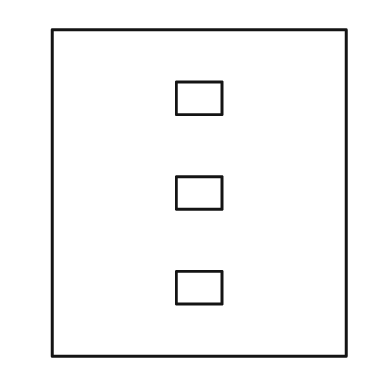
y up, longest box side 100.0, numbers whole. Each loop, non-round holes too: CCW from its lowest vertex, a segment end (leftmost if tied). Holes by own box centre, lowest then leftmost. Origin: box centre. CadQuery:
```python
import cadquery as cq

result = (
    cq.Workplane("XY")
    .moveTo(-45.0, -50.0)
    .lineTo(45.0, -50.0)
    .lineTo(45.0, 50.0)
    .lineTo(-45.0, 50.0)
    .close()
    .moveTo(-7.0, -34.0)
    .lineTo(7.0, -34.0)
    .lineTo(7.0, -24.0)
    .lineTo(-7.0, -24.0)
    .close()
    .moveTo(-7.0, -5.0)
    .lineTo(7.0, -5.0)
    .lineTo(7.0, 5.0)
    .lineTo(-7.0, 5.0)
    .close()
    .moveTo(-7.0, 24.0)
    .lineTo(7.0, 24.0)
    .lineTo(7.0, 34.0)
    .lineTo(-7.0, 34.0)
    .close()
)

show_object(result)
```